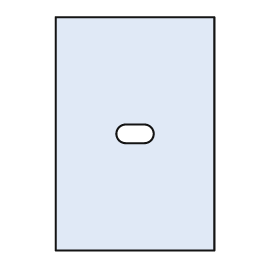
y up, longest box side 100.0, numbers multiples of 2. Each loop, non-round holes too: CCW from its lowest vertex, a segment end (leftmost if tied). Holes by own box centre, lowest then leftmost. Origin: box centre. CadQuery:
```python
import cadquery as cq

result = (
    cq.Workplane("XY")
    .moveTo(-34.0, -50.0)
    .lineTo(34.0, -50.0)
    .lineTo(34.0, 50.0)
    .lineTo(-34.0, 50.0)
    .close()
    .moveTo(-4.0, -4.0)
    .lineTo(4.0, -4.0)
    .threePointArc((8.0, 0.0), (4.0, 4.0))
    .lineTo(-4.0, 4.0)
    .threePointArc((-8.0, 0.0), (-4.0, -4.0))
    .close()
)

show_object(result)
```